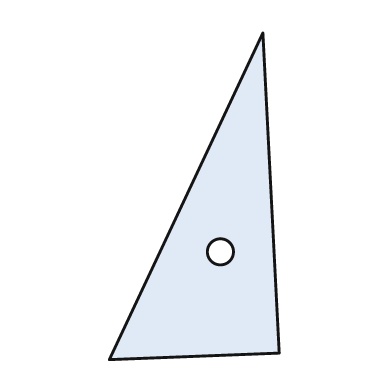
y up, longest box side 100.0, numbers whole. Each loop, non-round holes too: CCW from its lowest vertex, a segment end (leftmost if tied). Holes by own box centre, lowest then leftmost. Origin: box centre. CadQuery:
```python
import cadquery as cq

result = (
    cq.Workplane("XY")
    .moveTo(-26.0, -50.0)
    .lineTo(26.0, -48.0)
    .lineTo(21.0, 50.0)
    .close()
    .moveTo(8.0, -17.0)
    .circle(4.0)
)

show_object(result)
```